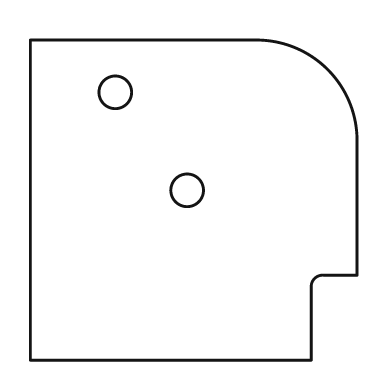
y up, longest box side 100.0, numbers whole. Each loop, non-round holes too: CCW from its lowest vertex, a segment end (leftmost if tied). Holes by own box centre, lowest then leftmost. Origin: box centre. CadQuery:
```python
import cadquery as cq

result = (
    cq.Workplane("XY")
    .moveTo(-50.0, -49.0)
    .lineTo(36.0, -49.0)
    .lineTo(36.0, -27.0)
    .threePointArc((37.0, -24.0), (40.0, -23.0))
    .lineTo(50.0, -23.0)
    .lineTo(50.0, 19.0)
    .threePointArc((41.0, 40.0), (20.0, 49.0))
    .lineTo(-50.0, 49.0)
    .close()
    .moveTo(-2.0, 3.0)
    .circle(5.0)
    .moveTo(-24.0, 33.0)
    .circle(5.0)
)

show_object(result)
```